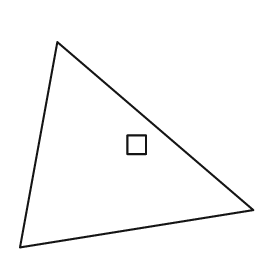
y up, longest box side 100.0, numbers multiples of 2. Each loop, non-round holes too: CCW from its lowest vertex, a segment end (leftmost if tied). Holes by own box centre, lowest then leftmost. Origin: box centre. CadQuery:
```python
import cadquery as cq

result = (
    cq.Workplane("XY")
    .moveTo(-50.0, -44.0)
    .lineTo(50.0, -28.0)
    .lineTo(-34.0, 44.0)
    .close()
    .moveTo(-4.0, -4.0)
    .lineTo(4.0, -4.0)
    .lineTo(4.0, 4.0)
    .lineTo(-4.0, 4.0)
    .close()
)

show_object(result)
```